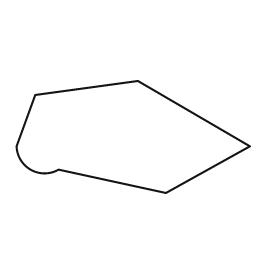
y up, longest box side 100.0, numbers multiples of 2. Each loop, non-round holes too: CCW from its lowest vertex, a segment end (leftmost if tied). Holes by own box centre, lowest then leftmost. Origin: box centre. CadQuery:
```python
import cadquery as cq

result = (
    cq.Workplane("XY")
    .moveTo(14.0, -24.0)
    .lineTo(50.0, -4.0)
    .lineTo(2.0, 24.0)
    .lineTo(-42.0, 18.0)
    .lineTo(-50.0, -4.0)
    .threePointArc((-44.0, -14.0), (-32.0, -14.0))
    .close()
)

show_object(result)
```